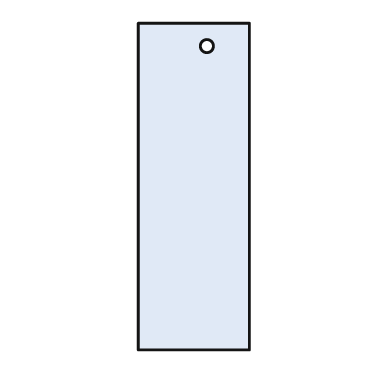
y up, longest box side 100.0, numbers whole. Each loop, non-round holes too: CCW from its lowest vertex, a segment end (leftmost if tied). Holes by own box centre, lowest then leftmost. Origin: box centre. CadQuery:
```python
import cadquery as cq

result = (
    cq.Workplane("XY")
    .moveTo(-17.0, -50.0)
    .lineTo(17.0, -50.0)
    .lineTo(17.0, 50.0)
    .lineTo(-17.0, 50.0)
    .close()
    .moveTo(4.0, 43.0)
    .circle(2.0)
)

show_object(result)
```